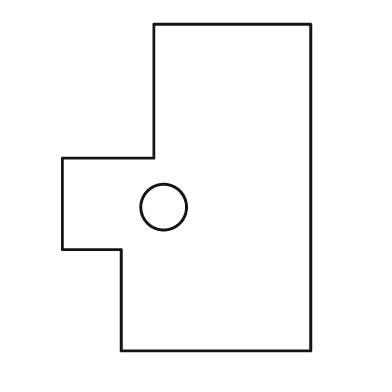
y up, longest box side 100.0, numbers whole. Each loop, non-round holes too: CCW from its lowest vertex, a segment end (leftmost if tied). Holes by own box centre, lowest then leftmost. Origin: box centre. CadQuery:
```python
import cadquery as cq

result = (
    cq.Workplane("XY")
    .moveTo(-20.0, -50.0)
    .lineTo(38.0, -50.0)
    .lineTo(38.0, 50.0)
    .lineTo(-10.0, 50.0)
    .lineTo(-10.0, 9.0)
    .lineTo(-38.0, 9.0)
    .lineTo(-38.0, -19.0)
    .lineTo(-20.0, -19.0)
    .close()
    .moveTo(-7.0, -6.0)
    .circle(7.0)
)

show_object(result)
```